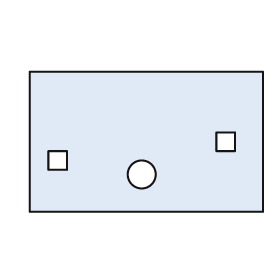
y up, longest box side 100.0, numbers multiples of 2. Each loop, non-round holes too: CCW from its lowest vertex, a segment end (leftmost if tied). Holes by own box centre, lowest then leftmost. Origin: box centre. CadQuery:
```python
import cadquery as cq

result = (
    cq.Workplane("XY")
    .moveTo(-50.0, -30.0)
    .lineTo(50.0, -30.0)
    .lineTo(50.0, 30.0)
    .lineTo(-50.0, 30.0)
    .close()
    .moveTo(-2.0, -14.0)
    .circle(6.0)
    .moveTo(-42.0, -12.0)
    .lineTo(-34.0, -12.0)
    .lineTo(-34.0, -4.0)
    .lineTo(-42.0, -4.0)
    .close()
    .moveTo(30.0, -4.0)
    .lineTo(38.0, -4.0)
    .lineTo(38.0, 4.0)
    .lineTo(30.0, 4.0)
    .close()
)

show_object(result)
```